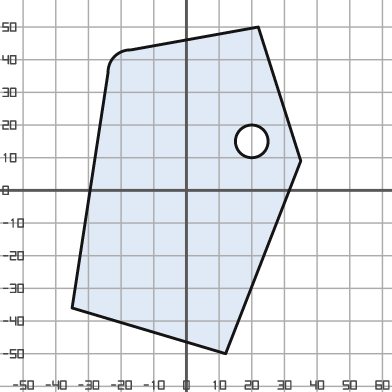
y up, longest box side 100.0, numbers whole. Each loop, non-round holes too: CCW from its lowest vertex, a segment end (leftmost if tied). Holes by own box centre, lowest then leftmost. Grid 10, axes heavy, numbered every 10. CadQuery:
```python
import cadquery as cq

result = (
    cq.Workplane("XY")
    .moveTo(12.0, -50.0)
    .lineTo(35.0, 9.0)
    .lineTo(22.0, 50.0)
    .lineTo(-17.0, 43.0)
    .threePointArc((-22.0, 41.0), (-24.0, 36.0))
    .lineTo(-35.0, -36.0)
    .close()
    .moveTo(20.0, 15.0)
    .circle(5.0)
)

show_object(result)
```